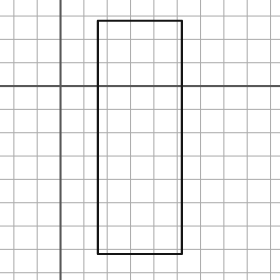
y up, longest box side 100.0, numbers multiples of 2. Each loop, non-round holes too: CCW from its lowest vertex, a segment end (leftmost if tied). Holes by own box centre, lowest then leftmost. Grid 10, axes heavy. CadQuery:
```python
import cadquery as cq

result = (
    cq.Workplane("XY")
    .moveTo(16.0, -72.0)
    .lineTo(52.0, -72.0)
    .lineTo(52.0, 28.0)
    .lineTo(16.0, 28.0)
    .close()
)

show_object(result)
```